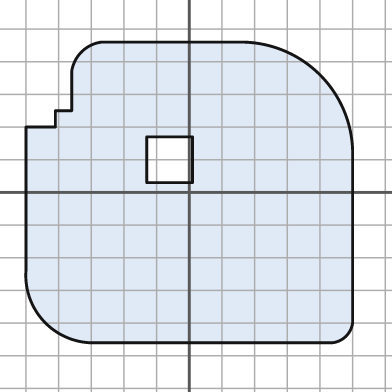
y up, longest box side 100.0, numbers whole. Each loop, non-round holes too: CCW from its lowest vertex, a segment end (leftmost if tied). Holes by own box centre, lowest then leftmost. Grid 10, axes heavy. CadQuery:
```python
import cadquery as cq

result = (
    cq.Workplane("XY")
    .moveTo(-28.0, -46.0)
    .lineTo(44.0, -46.0)
    .threePointArc((48.0, -44.0), (50.0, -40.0))
    .lineTo(50.0, 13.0)
    .threePointArc((40.0, 36.0), (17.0, 46.0))
    .lineTo(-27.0, 46.0)
    .threePointArc((-33.0, 43.0), (-36.0, 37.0))
    .lineTo(-36.0, 25.0)
    .lineTo(-41.0, 25.0)
    .lineTo(-41.0, 20.0)
    .lineTo(-50.0, 20.0)
    .lineTo(-50.0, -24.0)
    .threePointArc((-44.0, -40.0), (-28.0, -46.0))
    .close()
    .moveTo(-13.0, 3.0)
    .lineTo(1.0, 3.0)
    .lineTo(1.0, 17.0)
    .lineTo(-13.0, 17.0)
    .close()
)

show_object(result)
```